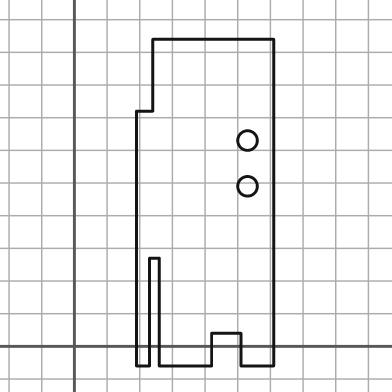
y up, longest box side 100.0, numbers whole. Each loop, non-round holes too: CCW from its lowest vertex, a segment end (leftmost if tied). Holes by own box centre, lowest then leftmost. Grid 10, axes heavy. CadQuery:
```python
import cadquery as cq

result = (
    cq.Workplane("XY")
    .moveTo(19.0, -6.0)
    .lineTo(23.0, -6.0)
    .lineTo(23.0, 27.0)
    .lineTo(26.0, 27.0)
    .lineTo(26.0, -6.0)
    .lineTo(42.0, -6.0)
    .lineTo(42.0, 4.0)
    .lineTo(51.0, 4.0)
    .lineTo(51.0, -6.0)
    .lineTo(61.0, -6.0)
    .lineTo(61.0, 94.0)
    .lineTo(24.0, 94.0)
    .lineTo(24.0, 72.0)
    .lineTo(19.0, 72.0)
    .close()
    .moveTo(53.0, 49.0)
    .circle(3.0)
    .moveTo(53.0, 63.0)
    .circle(3.0)
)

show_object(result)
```